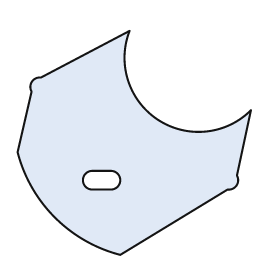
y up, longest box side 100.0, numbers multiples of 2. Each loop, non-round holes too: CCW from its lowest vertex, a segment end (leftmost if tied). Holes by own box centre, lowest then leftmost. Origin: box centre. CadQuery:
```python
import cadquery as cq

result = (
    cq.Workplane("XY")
    .moveTo(-6.0, -48.0)
    .lineTo(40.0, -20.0)
    .threePointArc((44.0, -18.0), (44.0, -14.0))
    .lineTo(50.0, 14.0)
    .threePointArc((10.0, 10.0), (-2.0, 48.0))
    .lineTo(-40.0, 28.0)
    .threePointArc((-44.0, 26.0), (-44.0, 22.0))
    .lineTo(-50.0, -4.0)
    .threePointArc((-34.0, -32.0), (-6.0, -48.0))
    .close()
    .moveTo(-18.0, -20.0)
    .lineTo(-10.0, -20.0)
    .threePointArc((-6.0, -16.0), (-10.0, -12.0))
    .lineTo(-18.0, -12.0)
    .threePointArc((-22.0, -16.0), (-18.0, -20.0))
    .close()
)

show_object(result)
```